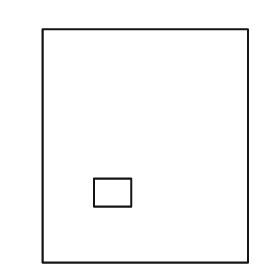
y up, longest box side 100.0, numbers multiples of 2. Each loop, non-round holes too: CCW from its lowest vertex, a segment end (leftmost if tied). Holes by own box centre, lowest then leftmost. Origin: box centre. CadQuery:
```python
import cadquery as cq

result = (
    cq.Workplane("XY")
    .moveTo(-44.0, -50.0)
    .lineTo(44.0, -50.0)
    .lineTo(44.0, 50.0)
    .lineTo(-44.0, 50.0)
    .close()
    .moveTo(-22.0, -26.0)
    .lineTo(-6.0, -26.0)
    .lineTo(-6.0, -14.0)
    .lineTo(-22.0, -14.0)
    .close()
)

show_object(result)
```